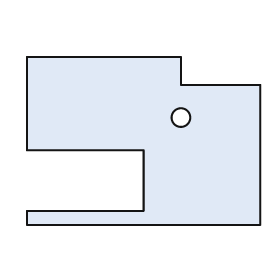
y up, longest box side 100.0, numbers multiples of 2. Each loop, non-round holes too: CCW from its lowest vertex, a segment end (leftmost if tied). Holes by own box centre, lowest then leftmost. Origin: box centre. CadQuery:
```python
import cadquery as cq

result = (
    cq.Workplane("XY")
    .moveTo(-50.0, -36.0)
    .lineTo(50.0, -36.0)
    .lineTo(50.0, 24.0)
    .lineTo(16.0, 24.0)
    .lineTo(16.0, 36.0)
    .lineTo(-50.0, 36.0)
    .lineTo(-50.0, -4.0)
    .lineTo(0.0, -4.0)
    .lineTo(0.0, -30.0)
    .lineTo(-50.0, -30.0)
    .close()
    .moveTo(16.0, 10.0)
    .circle(4.0)
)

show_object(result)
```